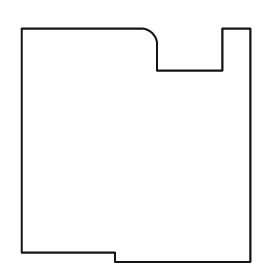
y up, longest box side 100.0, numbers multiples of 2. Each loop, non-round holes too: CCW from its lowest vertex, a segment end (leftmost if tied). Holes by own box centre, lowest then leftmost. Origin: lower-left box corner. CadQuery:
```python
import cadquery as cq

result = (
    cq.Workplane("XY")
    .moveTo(40.0, 0.0)
    .lineTo(98.0, 0.0)
    .lineTo(98.0, 100.0)
    .lineTo(86.0, 100.0)
    .lineTo(86.0, 82.0)
    .lineTo(58.0, 82.0)
    .lineTo(58.0, 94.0)
    .threePointArc((56.0, 98.0), (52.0, 100.0))
    .lineTo(0.0, 100.0)
    .lineTo(0.0, 4.0)
    .lineTo(40.0, 4.0)
    .close()
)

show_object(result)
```